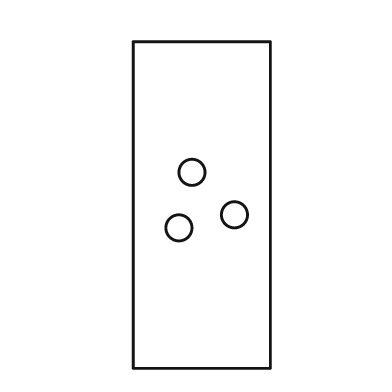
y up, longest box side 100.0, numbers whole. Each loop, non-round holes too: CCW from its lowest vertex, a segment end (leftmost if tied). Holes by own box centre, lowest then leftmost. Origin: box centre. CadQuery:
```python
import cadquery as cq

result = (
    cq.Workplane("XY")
    .moveTo(-21.0, -50.0)
    .lineTo(21.0, -50.0)
    .lineTo(21.0, 50.0)
    .lineTo(-21.0, 50.0)
    .close()
    .moveTo(-7.0, -7.0)
    .circle(4.0)
    .moveTo(10.0, -3.0)
    .circle(4.0)
    .moveTo(-3.0, 10.0)
    .circle(4.0)
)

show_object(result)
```